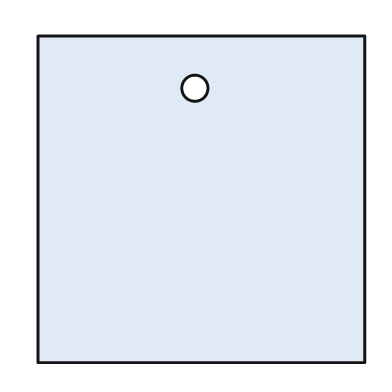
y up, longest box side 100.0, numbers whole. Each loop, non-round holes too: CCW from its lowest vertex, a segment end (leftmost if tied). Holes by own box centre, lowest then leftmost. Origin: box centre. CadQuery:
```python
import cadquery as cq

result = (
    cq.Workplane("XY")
    .moveTo(-50.0, -50.0)
    .lineTo(50.0, -50.0)
    .lineTo(50.0, 50.0)
    .lineTo(-50.0, 50.0)
    .close()
    .moveTo(-2.0, 34.0)
    .circle(4.0)
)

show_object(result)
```